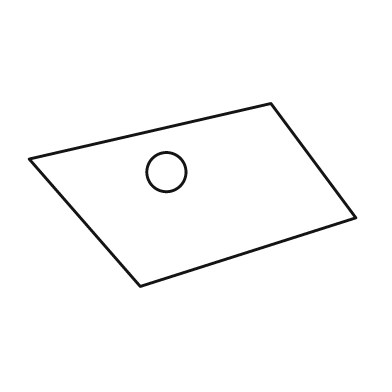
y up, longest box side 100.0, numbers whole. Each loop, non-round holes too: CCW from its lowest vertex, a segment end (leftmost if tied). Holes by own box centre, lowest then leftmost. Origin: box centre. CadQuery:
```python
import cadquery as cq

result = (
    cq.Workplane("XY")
    .moveTo(-16.0, -28.0)
    .lineTo(50.0, -7.0)
    .lineTo(24.0, 28.0)
    .lineTo(-50.0, 11.0)
    .close()
    .moveTo(-8.0, 7.0)
    .circle(6.0)
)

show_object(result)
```